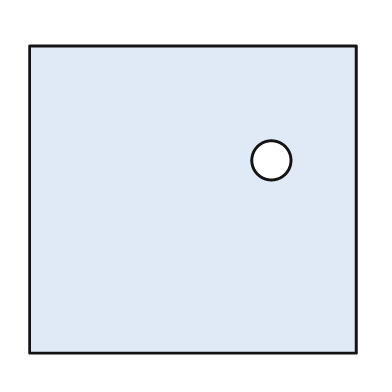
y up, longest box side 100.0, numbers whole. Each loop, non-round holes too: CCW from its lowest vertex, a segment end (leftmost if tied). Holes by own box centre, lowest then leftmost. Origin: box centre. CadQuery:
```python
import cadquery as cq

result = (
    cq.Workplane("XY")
    .moveTo(-50.0, -47.0)
    .lineTo(50.0, -47.0)
    .lineTo(50.0, 47.0)
    .lineTo(-50.0, 47.0)
    .close()
    .moveTo(24.0, 12.0)
    .circle(6.0)
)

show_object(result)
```